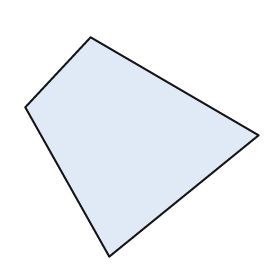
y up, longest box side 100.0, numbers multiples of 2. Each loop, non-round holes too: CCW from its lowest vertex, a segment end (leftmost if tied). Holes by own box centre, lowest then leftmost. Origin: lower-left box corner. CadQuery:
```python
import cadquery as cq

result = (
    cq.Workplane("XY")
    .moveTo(36.0, 0.0)
    .lineTo(100.0, 52.0)
    .lineTo(28.0, 94.0)
    .lineTo(0.0, 64.0)
    .close()
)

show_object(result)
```